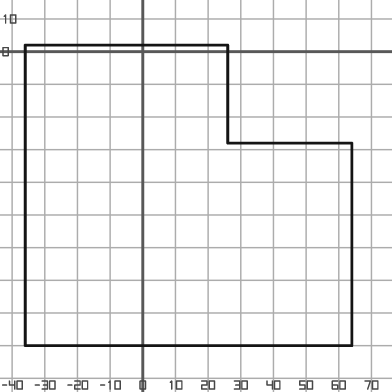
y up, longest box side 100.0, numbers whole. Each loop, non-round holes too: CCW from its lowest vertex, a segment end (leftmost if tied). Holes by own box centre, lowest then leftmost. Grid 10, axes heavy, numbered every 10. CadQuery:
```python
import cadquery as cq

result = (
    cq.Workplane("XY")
    .moveTo(-36.0, -90.0)
    .lineTo(64.0, -90.0)
    .lineTo(64.0, -28.0)
    .lineTo(26.0, -28.0)
    .lineTo(26.0, 2.0)
    .lineTo(-36.0, 2.0)
    .close()
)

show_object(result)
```